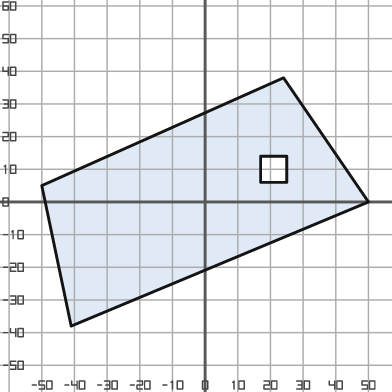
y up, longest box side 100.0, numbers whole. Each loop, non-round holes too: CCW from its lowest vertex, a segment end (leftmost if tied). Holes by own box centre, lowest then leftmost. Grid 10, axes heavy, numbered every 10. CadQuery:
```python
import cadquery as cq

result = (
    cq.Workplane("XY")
    .moveTo(-41.0, -38.0)
    .lineTo(50.0, 0.0)
    .lineTo(24.0, 38.0)
    .lineTo(-50.0, 5.0)
    .close()
    .moveTo(17.0, 6.0)
    .lineTo(25.0, 6.0)
    .lineTo(25.0, 14.0)
    .lineTo(17.0, 14.0)
    .close()
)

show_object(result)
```